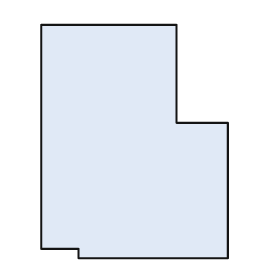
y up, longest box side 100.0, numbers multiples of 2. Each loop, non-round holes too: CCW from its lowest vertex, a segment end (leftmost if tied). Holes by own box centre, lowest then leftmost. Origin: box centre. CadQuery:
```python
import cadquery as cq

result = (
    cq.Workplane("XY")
    .moveTo(-24.0, -50.0)
    .lineTo(40.0, -50.0)
    .lineTo(40.0, 8.0)
    .lineTo(18.0, 8.0)
    .lineTo(18.0, 50.0)
    .lineTo(-40.0, 50.0)
    .lineTo(-40.0, -46.0)
    .lineTo(-24.0, -46.0)
    .close()
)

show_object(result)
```